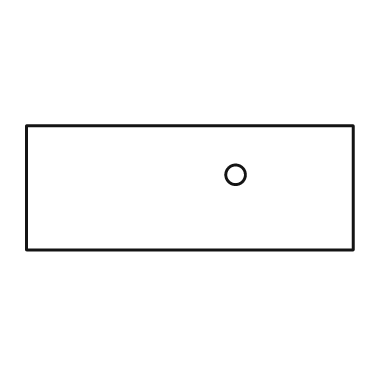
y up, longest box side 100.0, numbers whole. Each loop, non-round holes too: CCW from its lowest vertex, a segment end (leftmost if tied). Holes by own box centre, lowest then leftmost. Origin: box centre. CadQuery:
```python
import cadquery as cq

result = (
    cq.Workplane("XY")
    .moveTo(-50.0, -19.0)
    .lineTo(50.0, -19.0)
    .lineTo(50.0, 19.0)
    .lineTo(-50.0, 19.0)
    .close()
    .moveTo(14.0, 4.0)
    .circle(3.0)
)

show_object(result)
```